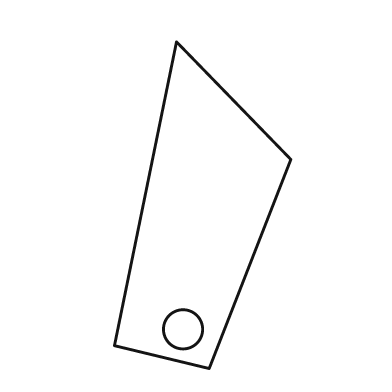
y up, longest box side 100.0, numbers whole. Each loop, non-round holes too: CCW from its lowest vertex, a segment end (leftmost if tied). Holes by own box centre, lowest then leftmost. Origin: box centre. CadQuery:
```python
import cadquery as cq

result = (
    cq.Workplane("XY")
    .moveTo(2.0, -50.0)
    .lineTo(27.0, 14.0)
    .lineTo(-8.0, 50.0)
    .lineTo(-27.0, -43.0)
    .close()
    .moveTo(-6.0, -38.0)
    .circle(6.0)
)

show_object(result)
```